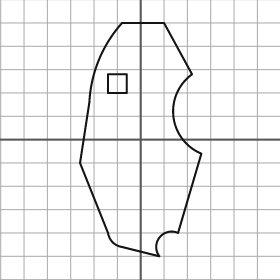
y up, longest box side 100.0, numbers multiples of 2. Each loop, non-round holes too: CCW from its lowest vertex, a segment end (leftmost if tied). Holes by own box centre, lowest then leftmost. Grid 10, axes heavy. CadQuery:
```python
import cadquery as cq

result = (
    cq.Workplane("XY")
    .moveTo(8.0, -50.0)
    .threePointArc((8.0, -42.0), (16.0, -40.0))
    .lineTo(26.0, -6.0)
    .threePointArc((14.0, 10.0), (22.0, 28.0))
    .lineTo(10.0, 50.0)
    .lineTo(-8.0, 50.0)
    .threePointArc((-18.0, 34.0), (-22.0, 16.0))
    .lineTo(-26.0, -10.0)
    .lineTo(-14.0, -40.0)
    .threePointArc((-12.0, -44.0), (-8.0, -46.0))
    .close()
    .moveTo(-14.0, 20.0)
    .lineTo(-6.0, 20.0)
    .lineTo(-6.0, 28.0)
    .lineTo(-14.0, 28.0)
    .close()
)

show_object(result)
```